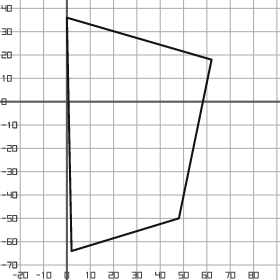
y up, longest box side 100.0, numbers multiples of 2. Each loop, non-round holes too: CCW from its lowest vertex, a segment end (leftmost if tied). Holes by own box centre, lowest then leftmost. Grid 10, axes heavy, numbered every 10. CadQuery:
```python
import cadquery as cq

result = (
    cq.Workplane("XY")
    .moveTo(2.0, -64.0)
    .lineTo(48.0, -50.0)
    .lineTo(62.0, 18.0)
    .lineTo(0.0, 36.0)
    .close()
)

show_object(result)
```